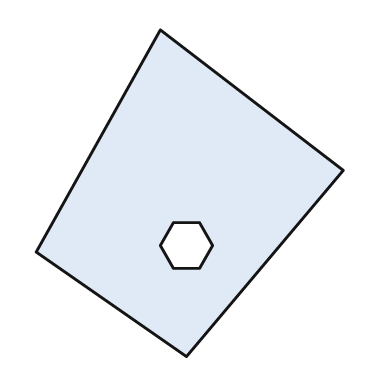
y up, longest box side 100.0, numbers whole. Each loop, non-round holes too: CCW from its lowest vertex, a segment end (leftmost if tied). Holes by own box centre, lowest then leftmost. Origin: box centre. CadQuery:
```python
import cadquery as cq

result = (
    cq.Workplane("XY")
    .moveTo(-1.0, -50.0)
    .lineTo(47.0, 7.0)
    .lineTo(-9.0, 50.0)
    .lineTo(-47.0, -18.0)
    .close()
    .moveTo(-5.0, -23.0)
    .lineTo(3.0, -23.0)
    .lineTo(7.0, -16.0)
    .lineTo(3.0, -9.0)
    .lineTo(-5.0, -9.0)
    .lineTo(-9.0, -16.0)
    .close()
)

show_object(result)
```